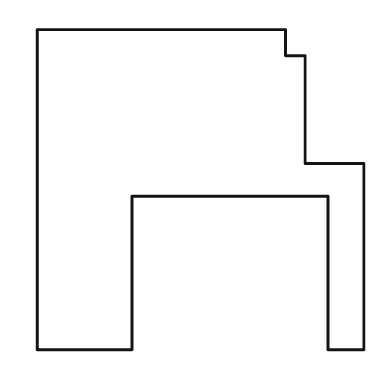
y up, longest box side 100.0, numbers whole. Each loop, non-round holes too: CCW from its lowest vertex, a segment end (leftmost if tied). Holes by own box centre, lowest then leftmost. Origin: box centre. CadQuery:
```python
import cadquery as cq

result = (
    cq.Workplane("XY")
    .moveTo(-50.0, -49.0)
    .lineTo(-21.0, -49.0)
    .lineTo(-21.0, -2.0)
    .lineTo(39.0, -2.0)
    .lineTo(39.0, -49.0)
    .lineTo(50.0, -49.0)
    .lineTo(50.0, 8.0)
    .lineTo(32.0, 8.0)
    .lineTo(32.0, 41.0)
    .lineTo(26.0, 41.0)
    .lineTo(26.0, 49.0)
    .lineTo(-50.0, 49.0)
    .close()
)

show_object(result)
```